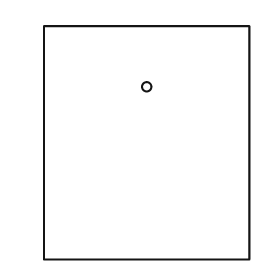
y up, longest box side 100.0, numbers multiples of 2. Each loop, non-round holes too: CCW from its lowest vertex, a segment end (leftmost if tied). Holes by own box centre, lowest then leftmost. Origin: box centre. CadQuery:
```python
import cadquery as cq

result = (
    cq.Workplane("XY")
    .moveTo(-44.0, -50.0)
    .lineTo(44.0, -50.0)
    .lineTo(44.0, 50.0)
    .lineTo(-44.0, 50.0)
    .close()
    .moveTo(0.0, 24.0)
    .circle(2.0)
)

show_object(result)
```